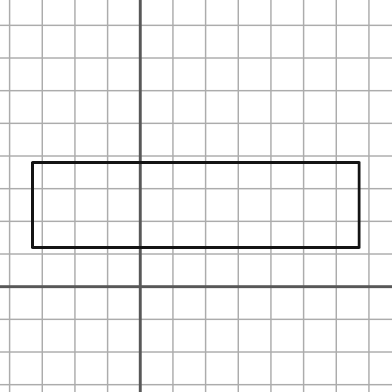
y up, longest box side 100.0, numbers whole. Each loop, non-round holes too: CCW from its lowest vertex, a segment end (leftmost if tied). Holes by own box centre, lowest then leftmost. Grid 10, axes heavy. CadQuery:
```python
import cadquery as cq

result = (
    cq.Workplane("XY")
    .moveTo(-33.0, 12.0)
    .lineTo(67.0, 12.0)
    .lineTo(67.0, 38.0)
    .lineTo(-33.0, 38.0)
    .close()
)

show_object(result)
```